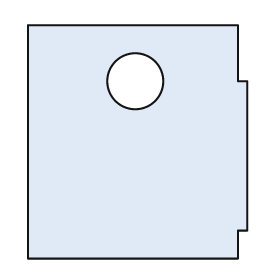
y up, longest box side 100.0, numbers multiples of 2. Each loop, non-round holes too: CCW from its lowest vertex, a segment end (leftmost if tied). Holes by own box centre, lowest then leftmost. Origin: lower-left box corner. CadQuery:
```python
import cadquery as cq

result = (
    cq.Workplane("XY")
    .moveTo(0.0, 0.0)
    .lineTo(90.0, 0.0)
    .lineTo(90.0, 12.0)
    .lineTo(94.0, 12.0)
    .lineTo(94.0, 76.0)
    .lineTo(90.0, 76.0)
    .lineTo(90.0, 100.0)
    .lineTo(0.0, 100.0)
    .close()
    .moveTo(46.0, 76.0)
    .circle(12.0)
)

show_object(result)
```